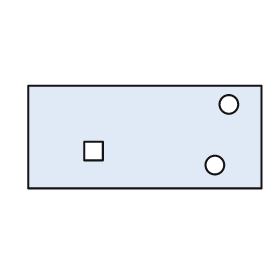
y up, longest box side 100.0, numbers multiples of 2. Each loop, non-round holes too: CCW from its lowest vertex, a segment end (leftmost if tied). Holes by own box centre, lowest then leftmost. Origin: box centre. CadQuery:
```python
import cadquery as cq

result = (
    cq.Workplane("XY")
    .moveTo(-50.0, -22.0)
    .lineTo(50.0, -22.0)
    .lineTo(50.0, 22.0)
    .lineTo(-50.0, 22.0)
    .close()
    .moveTo(30.0, -12.0)
    .circle(4.0)
    .moveTo(-26.0, -10.0)
    .lineTo(-18.0, -10.0)
    .lineTo(-18.0, -2.0)
    .lineTo(-26.0, -2.0)
    .close()
    .moveTo(36.0, 14.0)
    .circle(4.0)
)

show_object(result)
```